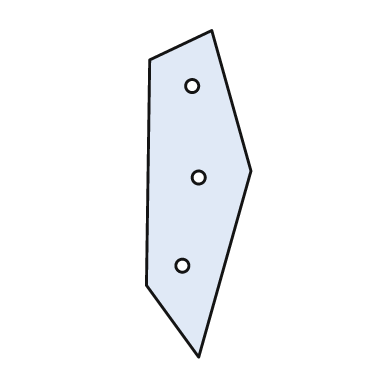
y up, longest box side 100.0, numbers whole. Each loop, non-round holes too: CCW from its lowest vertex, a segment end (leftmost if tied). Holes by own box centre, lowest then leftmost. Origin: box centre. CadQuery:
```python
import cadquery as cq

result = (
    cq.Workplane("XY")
    .moveTo(0.0, -50.0)
    .lineTo(16.0, 7.0)
    .lineTo(4.0, 50.0)
    .lineTo(-15.0, 41.0)
    .lineTo(-16.0, -28.0)
    .close()
    .moveTo(-5.0, -22.0)
    .circle(2.0)
    .moveTo(0.0, 5.0)
    .circle(2.0)
    .moveTo(-2.0, 33.0)
    .circle(2.0)
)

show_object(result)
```